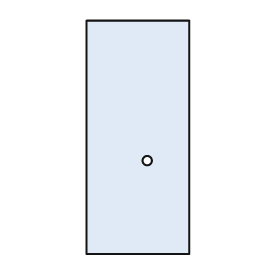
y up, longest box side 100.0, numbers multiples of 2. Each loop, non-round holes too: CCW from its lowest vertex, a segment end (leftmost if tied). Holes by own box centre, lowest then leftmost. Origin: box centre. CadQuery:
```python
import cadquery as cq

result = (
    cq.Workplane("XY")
    .moveTo(-22.0, -50.0)
    .lineTo(22.0, -50.0)
    .lineTo(22.0, 50.0)
    .lineTo(-22.0, 50.0)
    .close()
    .moveTo(4.0, -10.0)
    .circle(2.0)
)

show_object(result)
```